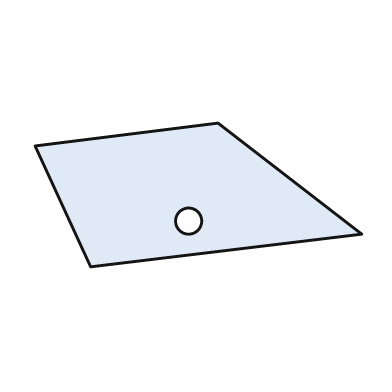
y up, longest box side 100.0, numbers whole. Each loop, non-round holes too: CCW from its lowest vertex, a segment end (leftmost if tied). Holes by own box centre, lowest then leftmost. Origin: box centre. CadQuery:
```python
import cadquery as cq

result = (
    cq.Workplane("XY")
    .moveTo(-33.0, -22.0)
    .lineTo(50.0, -12.0)
    .lineTo(6.0, 22.0)
    .lineTo(-50.0, 15.0)
    .close()
    .moveTo(-3.0, -8.0)
    .circle(4.0)
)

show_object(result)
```